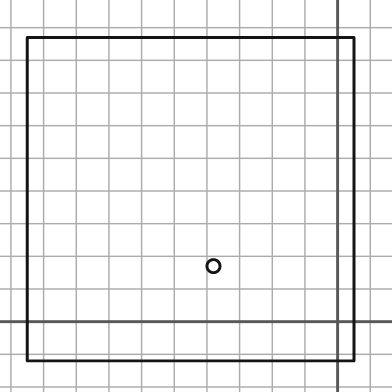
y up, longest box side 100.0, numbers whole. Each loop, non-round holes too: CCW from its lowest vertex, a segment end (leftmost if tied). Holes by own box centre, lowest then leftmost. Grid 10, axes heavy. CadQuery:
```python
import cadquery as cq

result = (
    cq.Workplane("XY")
    .moveTo(-95.0, -12.0)
    .lineTo(5.0, -12.0)
    .lineTo(5.0, 87.0)
    .lineTo(-95.0, 87.0)
    .close()
    .moveTo(-38.0, 17.0)
    .circle(2.0)
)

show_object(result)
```